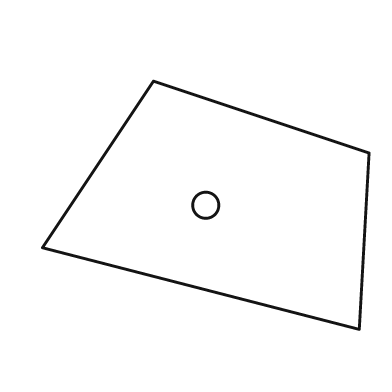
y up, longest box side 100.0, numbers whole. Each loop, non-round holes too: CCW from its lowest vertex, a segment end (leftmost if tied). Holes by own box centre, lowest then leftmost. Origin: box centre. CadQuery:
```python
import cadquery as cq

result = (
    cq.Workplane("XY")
    .moveTo(47.0, -38.0)
    .lineTo(50.0, 16.0)
    .lineTo(-16.0, 38.0)
    .lineTo(-50.0, -13.0)
    .close()
    .moveTo(0.0, 0.0)
    .circle(4.0)
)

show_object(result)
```